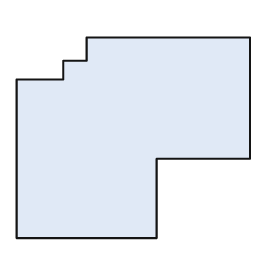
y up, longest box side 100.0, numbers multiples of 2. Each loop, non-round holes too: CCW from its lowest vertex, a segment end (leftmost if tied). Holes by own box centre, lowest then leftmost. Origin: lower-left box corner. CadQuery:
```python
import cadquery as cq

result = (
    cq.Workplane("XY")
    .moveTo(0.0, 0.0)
    .lineTo(60.0, 0.0)
    .lineTo(60.0, 34.0)
    .lineTo(100.0, 34.0)
    .lineTo(100.0, 86.0)
    .lineTo(30.0, 86.0)
    .lineTo(30.0, 76.0)
    .lineTo(20.0, 76.0)
    .lineTo(20.0, 68.0)
    .lineTo(0.0, 68.0)
    .close()
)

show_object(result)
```